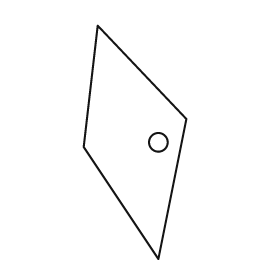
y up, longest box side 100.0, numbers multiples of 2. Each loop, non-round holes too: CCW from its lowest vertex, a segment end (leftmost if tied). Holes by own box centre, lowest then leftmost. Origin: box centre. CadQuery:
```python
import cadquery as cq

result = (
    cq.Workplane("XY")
    .moveTo(10.0, -50.0)
    .lineTo(22.0, 10.0)
    .lineTo(-16.0, 50.0)
    .lineTo(-22.0, -2.0)
    .close()
    .moveTo(10.0, 0.0)
    .circle(4.0)
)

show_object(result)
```